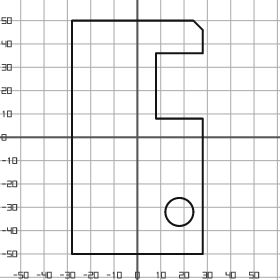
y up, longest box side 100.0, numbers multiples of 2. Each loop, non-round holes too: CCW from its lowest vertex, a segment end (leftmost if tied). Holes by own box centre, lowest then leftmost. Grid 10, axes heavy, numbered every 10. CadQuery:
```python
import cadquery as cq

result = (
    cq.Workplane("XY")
    .moveTo(-28.0, -50.0)
    .lineTo(28.0, -50.0)
    .lineTo(28.0, 8.0)
    .lineTo(8.0, 8.0)
    .lineTo(8.0, 36.0)
    .lineTo(28.0, 36.0)
    .lineTo(28.0, 46.0)
    .lineTo(24.0, 50.0)
    .lineTo(-28.0, 50.0)
    .close()
    .moveTo(18.0, -32.0)
    .circle(6.0)
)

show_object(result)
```